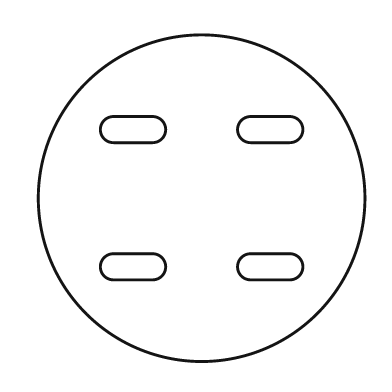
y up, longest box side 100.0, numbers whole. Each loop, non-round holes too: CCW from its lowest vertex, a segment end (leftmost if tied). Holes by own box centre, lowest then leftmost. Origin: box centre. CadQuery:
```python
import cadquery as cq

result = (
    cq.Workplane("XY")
    .moveTo(0.0, 0.0)
    .circle(50.0)
    .moveTo(-27.0, -25.0)
    .lineTo(-15.0, -25.0)
    .threePointArc((-11.0, -21.0), (-15.0, -17.0))
    .lineTo(-27.0, -17.0)
    .threePointArc((-31.0, -21.0), (-27.0, -25.0))
    .close()
    .moveTo(15.0, -25.0)
    .lineTo(27.0, -25.0)
    .threePointArc((31.0, -21.0), (27.0, -17.0))
    .lineTo(15.0, -17.0)
    .threePointArc((11.0, -21.0), (15.0, -25.0))
    .close()
    .moveTo(-27.0, 17.0)
    .lineTo(-15.0, 17.0)
    .threePointArc((-11.0, 21.0), (-15.0, 25.0))
    .lineTo(-27.0, 25.0)
    .threePointArc((-31.0, 21.0), (-27.0, 17.0))
    .close()
    .moveTo(15.0, 17.0)
    .lineTo(27.0, 17.0)
    .threePointArc((31.0, 21.0), (27.0, 25.0))
    .lineTo(15.0, 25.0)
    .threePointArc((11.0, 21.0), (15.0, 17.0))
    .close()
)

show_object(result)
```